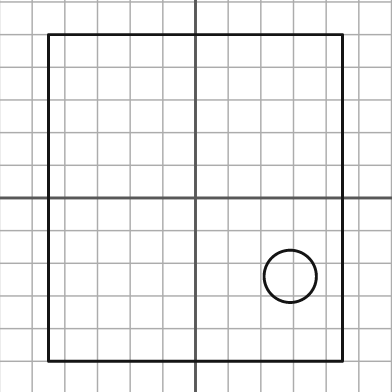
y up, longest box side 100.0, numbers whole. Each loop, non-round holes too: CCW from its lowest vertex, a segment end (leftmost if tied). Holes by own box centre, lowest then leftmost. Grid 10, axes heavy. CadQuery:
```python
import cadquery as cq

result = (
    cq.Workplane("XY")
    .moveTo(-45.0, -50.0)
    .lineTo(45.0, -50.0)
    .lineTo(45.0, 50.0)
    .lineTo(-45.0, 50.0)
    .close()
    .moveTo(29.0, -24.0)
    .circle(8.0)
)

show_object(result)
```